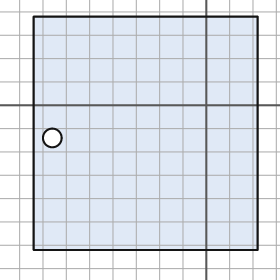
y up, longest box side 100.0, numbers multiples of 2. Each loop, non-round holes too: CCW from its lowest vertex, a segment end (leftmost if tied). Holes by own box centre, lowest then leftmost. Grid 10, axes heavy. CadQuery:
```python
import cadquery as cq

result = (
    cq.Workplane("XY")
    .moveTo(-74.0, -62.0)
    .lineTo(22.0, -62.0)
    .lineTo(22.0, 38.0)
    .lineTo(-74.0, 38.0)
    .close()
    .moveTo(-66.0, -14.0)
    .circle(4.0)
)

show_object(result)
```